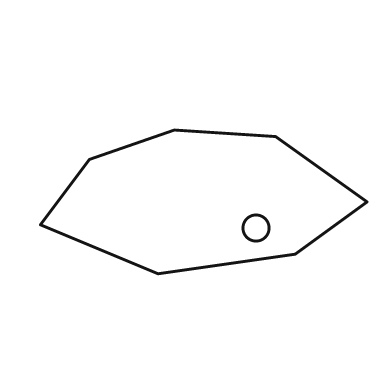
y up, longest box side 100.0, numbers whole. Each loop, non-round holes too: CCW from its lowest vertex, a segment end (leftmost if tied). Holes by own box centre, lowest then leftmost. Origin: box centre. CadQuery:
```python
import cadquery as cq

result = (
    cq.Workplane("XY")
    .moveTo(-14.0, -22.0)
    .lineTo(28.0, -16.0)
    .lineTo(50.0, 0.0)
    .lineTo(22.0, 20.0)
    .lineTo(-9.0, 22.0)
    .lineTo(-35.0, 13.0)
    .lineTo(-50.0, -7.0)
    .close()
    .moveTo(16.0, -8.0)
    .circle(4.0)
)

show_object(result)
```